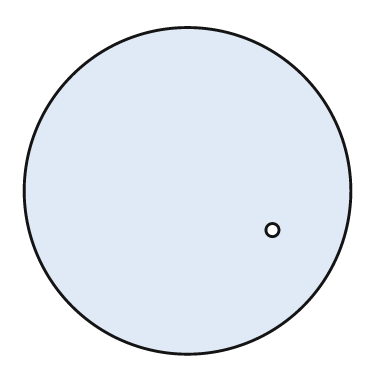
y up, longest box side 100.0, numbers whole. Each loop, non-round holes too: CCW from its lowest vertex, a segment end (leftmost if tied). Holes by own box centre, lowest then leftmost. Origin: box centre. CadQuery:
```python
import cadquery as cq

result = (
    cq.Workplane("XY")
    .moveTo(0.0, 0.0)
    .circle(50.0)
    .moveTo(26.0, -12.0)
    .circle(2.0)
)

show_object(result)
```